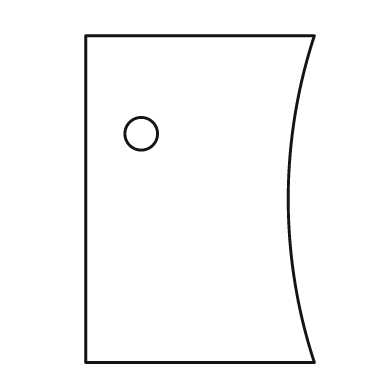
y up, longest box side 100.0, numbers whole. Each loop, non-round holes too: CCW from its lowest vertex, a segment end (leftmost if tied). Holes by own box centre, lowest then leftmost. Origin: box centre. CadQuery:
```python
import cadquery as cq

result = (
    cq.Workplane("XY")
    .moveTo(-35.0, -50.0)
    .lineTo(35.0, -50.0)
    .threePointArc((27.0, 0.0), (35.0, 50.0))
    .lineTo(-35.0, 50.0)
    .close()
    .moveTo(-18.0, 20.0)
    .circle(5.0)
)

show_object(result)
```